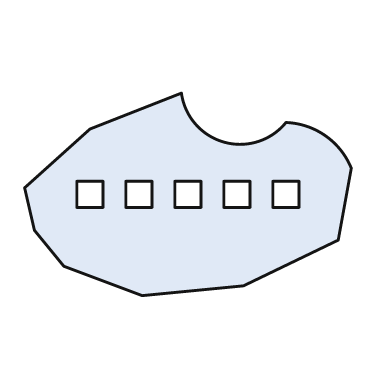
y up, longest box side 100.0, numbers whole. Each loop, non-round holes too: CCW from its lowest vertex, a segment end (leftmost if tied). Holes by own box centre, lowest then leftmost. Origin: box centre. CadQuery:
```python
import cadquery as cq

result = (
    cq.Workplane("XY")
    .moveTo(-14.0, -31.0)
    .lineTo(17.0, -28.0)
    .lineTo(46.0, -14.0)
    .lineTo(50.0, 8.0)
    .threePointArc((42.0, 18.0), (30.0, 22.0))
    .threePointArc((11.0, 16.0), (-2.0, 31.0))
    .lineTo(-30.0, 20.0)
    .lineTo(-50.0, 2.0)
    .lineTo(-47.0, -11.0)
    .lineTo(-38.0, -22.0)
    .close()
    .moveTo(-34.0, -4.0)
    .lineTo(-26.0, -4.0)
    .lineTo(-26.0, 4.0)
    .lineTo(-34.0, 4.0)
    .close()
    .moveTo(-19.0, -4.0)
    .lineTo(-11.0, -4.0)
    .lineTo(-11.0, 4.0)
    .lineTo(-19.0, 4.0)
    .close()
    .moveTo(-4.0, -4.0)
    .lineTo(4.0, -4.0)
    .lineTo(4.0, 4.0)
    .lineTo(-4.0, 4.0)
    .close()
    .moveTo(11.0, -4.0)
    .lineTo(19.0, -4.0)
    .lineTo(19.0, 4.0)
    .lineTo(11.0, 4.0)
    .close()
    .moveTo(26.0, -4.0)
    .lineTo(34.0, -4.0)
    .lineTo(34.0, 4.0)
    .lineTo(26.0, 4.0)
    .close()
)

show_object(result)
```